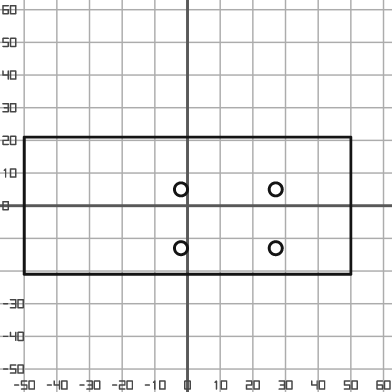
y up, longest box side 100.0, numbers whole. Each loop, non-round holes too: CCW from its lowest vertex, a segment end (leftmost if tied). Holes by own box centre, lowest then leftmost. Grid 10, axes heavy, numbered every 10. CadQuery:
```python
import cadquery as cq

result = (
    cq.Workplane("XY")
    .moveTo(-50.0, -21.0)
    .lineTo(50.0, -21.0)
    .lineTo(50.0, 21.0)
    .lineTo(-50.0, 21.0)
    .close()
    .moveTo(-2.0, -13.0)
    .circle(2.0)
    .moveTo(27.0, -13.0)
    .circle(2.0)
    .moveTo(-2.0, 5.0)
    .circle(2.0)
    .moveTo(27.0, 5.0)
    .circle(2.0)
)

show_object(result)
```